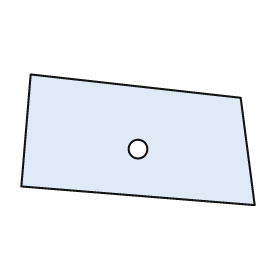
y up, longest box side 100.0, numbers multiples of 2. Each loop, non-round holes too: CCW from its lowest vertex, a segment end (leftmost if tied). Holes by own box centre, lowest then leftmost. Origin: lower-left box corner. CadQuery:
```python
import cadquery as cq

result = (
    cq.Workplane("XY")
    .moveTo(100.0, 0.0)
    .lineTo(94.0, 46.0)
    .lineTo(4.0, 56.0)
    .lineTo(0.0, 8.0)
    .close()
    .moveTo(50.0, 24.0)
    .circle(4.0)
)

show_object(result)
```